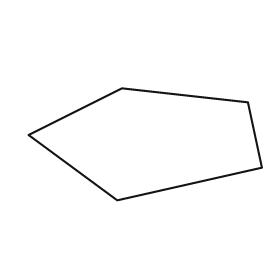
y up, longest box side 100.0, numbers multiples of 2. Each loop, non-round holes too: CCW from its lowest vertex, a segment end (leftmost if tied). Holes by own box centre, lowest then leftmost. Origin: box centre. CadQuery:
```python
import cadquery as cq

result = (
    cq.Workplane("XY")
    .moveTo(-12.0, -24.0)
    .lineTo(50.0, -10.0)
    .lineTo(44.0, 18.0)
    .lineTo(-10.0, 24.0)
    .lineTo(-50.0, 4.0)
    .close()
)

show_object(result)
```